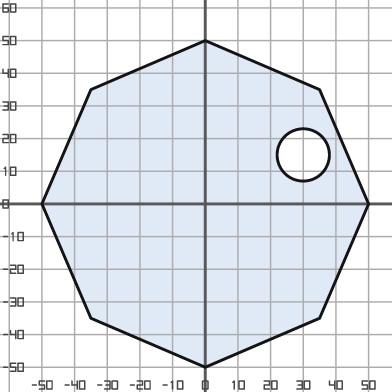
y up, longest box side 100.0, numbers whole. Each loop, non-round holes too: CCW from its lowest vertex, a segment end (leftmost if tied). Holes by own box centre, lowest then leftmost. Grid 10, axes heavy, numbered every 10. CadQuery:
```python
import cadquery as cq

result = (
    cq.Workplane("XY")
    .moveTo(0.0, -50.0)
    .lineTo(35.0, -35.0)
    .lineTo(50.0, 0.0)
    .lineTo(35.0, 35.0)
    .lineTo(0.0, 50.0)
    .lineTo(-35.0, 35.0)
    .lineTo(-50.0, 0.0)
    .lineTo(-35.0, -35.0)
    .close()
    .moveTo(30.0, 15.0)
    .circle(8.0)
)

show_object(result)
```